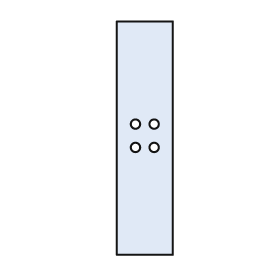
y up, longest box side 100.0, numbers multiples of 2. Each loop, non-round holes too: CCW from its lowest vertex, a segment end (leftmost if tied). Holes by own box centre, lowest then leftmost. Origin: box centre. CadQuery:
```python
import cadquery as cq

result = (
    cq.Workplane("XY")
    .moveTo(-12.0, -50.0)
    .lineTo(12.0, -50.0)
    .lineTo(12.0, 50.0)
    .lineTo(-12.0, 50.0)
    .close()
    .moveTo(-4.0, -4.0)
    .circle(2.0)
    .moveTo(4.0, -4.0)
    .circle(2.0)
    .moveTo(-4.0, 6.0)
    .circle(2.0)
    .moveTo(4.0, 6.0)
    .circle(2.0)
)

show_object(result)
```